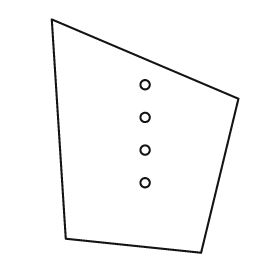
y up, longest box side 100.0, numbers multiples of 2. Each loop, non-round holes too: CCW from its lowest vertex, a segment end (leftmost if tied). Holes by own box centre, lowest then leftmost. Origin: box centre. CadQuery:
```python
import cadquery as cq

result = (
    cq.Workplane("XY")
    .moveTo(24.0, -50.0)
    .lineTo(40.0, 16.0)
    .lineTo(-40.0, 50.0)
    .lineTo(-34.0, -44.0)
    .close()
    .moveTo(0.0, -20.0)
    .circle(2.0)
    .moveTo(0.0, -6.0)
    .circle(2.0)
    .moveTo(0.0, 8.0)
    .circle(2.0)
    .moveTo(0.0, 22.0)
    .circle(2.0)
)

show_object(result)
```